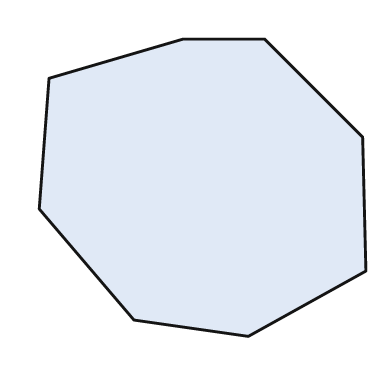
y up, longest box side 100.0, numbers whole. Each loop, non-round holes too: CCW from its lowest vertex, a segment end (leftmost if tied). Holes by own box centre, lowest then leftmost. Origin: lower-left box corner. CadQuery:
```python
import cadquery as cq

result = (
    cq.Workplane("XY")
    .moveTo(64.0, 0.0)
    .lineTo(100.0, 20.0)
    .lineTo(99.0, 61.0)
    .lineTo(69.0, 91.0)
    .lineTo(44.0, 91.0)
    .lineTo(3.0, 79.0)
    .lineTo(0.0, 39.0)
    .lineTo(29.0, 5.0)
    .close()
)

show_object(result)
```